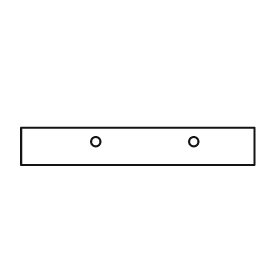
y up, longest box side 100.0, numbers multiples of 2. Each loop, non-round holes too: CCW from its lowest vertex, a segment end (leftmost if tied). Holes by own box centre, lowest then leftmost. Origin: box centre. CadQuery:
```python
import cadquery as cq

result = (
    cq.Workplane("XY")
    .moveTo(-50.0, -8.0)
    .lineTo(50.0, -8.0)
    .lineTo(50.0, 8.0)
    .lineTo(-50.0, 8.0)
    .close()
    .moveTo(-18.0, 2.0)
    .circle(2.0)
    .moveTo(24.0, 2.0)
    .circle(2.0)
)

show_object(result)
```